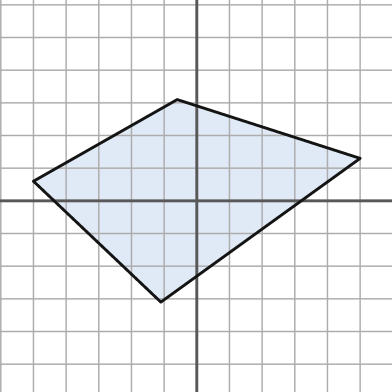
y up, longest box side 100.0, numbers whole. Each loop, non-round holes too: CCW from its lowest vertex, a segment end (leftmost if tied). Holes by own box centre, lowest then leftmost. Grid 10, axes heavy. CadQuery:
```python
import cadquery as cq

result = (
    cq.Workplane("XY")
    .moveTo(-11.0, -31.0)
    .lineTo(50.0, 13.0)
    .lineTo(-6.0, 31.0)
    .lineTo(-50.0, 6.0)
    .close()
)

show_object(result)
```